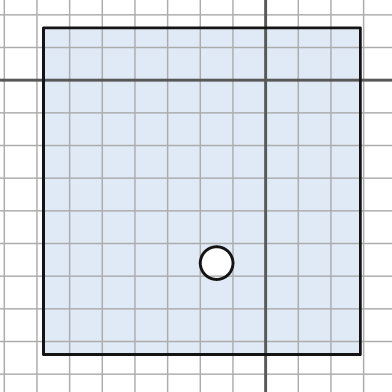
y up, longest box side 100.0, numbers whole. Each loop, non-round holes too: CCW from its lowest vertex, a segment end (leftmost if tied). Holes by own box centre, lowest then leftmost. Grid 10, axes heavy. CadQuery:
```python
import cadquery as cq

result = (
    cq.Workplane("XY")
    .moveTo(-68.0, -84.0)
    .lineTo(29.0, -84.0)
    .lineTo(29.0, 16.0)
    .lineTo(-68.0, 16.0)
    .close()
    .moveTo(-15.0, -56.0)
    .circle(5.0)
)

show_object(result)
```